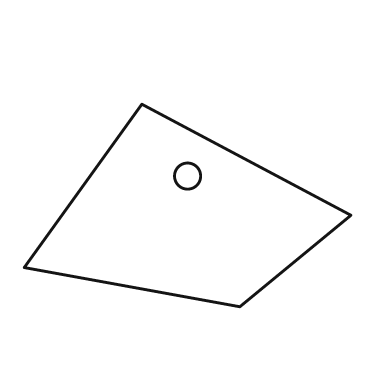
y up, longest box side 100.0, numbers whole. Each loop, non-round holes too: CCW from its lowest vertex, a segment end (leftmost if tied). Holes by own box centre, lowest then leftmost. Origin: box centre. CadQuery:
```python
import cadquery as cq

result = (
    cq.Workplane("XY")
    .moveTo(16.0, -31.0)
    .lineTo(50.0, -3.0)
    .lineTo(-14.0, 31.0)
    .lineTo(-50.0, -19.0)
    .close()
    .moveTo(0.0, 9.0)
    .circle(4.0)
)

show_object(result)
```